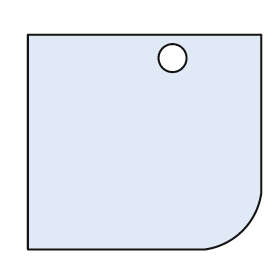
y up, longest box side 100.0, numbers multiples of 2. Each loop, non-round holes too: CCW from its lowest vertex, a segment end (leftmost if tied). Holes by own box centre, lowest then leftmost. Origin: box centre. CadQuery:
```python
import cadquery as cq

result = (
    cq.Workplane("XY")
    .moveTo(-50.0, -46.0)
    .lineTo(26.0, -46.0)
    .threePointArc((42.0, -38.0), (50.0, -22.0))
    .lineTo(50.0, 46.0)
    .lineTo(-50.0, 46.0)
    .close()
    .moveTo(12.0, 36.0)
    .circle(6.0)
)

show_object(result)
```